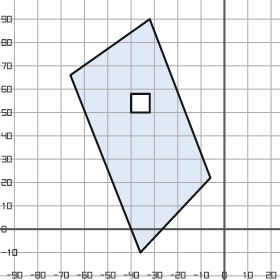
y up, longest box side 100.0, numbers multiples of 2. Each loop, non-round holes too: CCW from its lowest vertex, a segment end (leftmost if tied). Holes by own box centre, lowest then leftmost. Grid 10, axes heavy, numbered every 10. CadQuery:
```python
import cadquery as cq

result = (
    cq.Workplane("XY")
    .moveTo(-36.0, -10.0)
    .lineTo(-6.0, 22.0)
    .lineTo(-32.0, 90.0)
    .lineTo(-66.0, 66.0)
    .close()
    .moveTo(-40.0, 50.0)
    .lineTo(-32.0, 50.0)
    .lineTo(-32.0, 58.0)
    .lineTo(-40.0, 58.0)
    .close()
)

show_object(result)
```